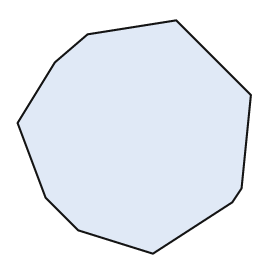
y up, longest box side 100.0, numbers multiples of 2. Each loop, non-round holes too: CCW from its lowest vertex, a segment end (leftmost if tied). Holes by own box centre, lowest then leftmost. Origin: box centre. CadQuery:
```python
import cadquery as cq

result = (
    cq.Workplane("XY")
    .moveTo(8.0, -50.0)
    .lineTo(42.0, -28.0)
    .lineTo(46.0, -22.0)
    .lineTo(50.0, 18.0)
    .lineTo(18.0, 50.0)
    .lineTo(-20.0, 44.0)
    .lineTo(-34.0, 32.0)
    .lineTo(-50.0, 6.0)
    .lineTo(-38.0, -26.0)
    .lineTo(-24.0, -40.0)
    .close()
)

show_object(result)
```